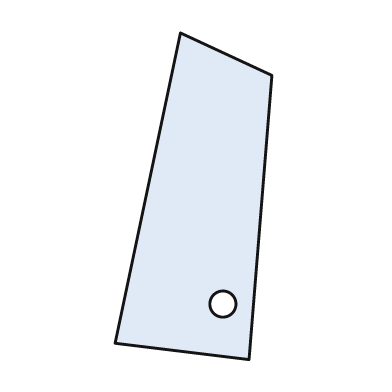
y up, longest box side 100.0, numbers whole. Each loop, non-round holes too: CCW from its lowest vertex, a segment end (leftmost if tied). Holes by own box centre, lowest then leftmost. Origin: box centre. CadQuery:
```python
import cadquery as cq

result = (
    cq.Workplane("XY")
    .moveTo(17.0, -50.0)
    .lineTo(24.0, 37.0)
    .lineTo(-4.0, 50.0)
    .lineTo(-24.0, -45.0)
    .close()
    .moveTo(9.0, -33.0)
    .circle(4.0)
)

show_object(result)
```